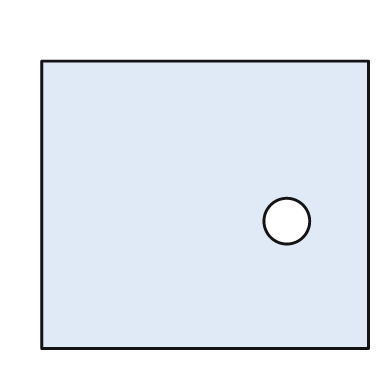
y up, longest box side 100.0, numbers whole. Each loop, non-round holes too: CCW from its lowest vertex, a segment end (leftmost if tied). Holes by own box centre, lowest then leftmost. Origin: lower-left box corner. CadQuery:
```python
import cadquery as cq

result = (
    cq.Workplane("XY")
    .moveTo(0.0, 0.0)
    .lineTo(100.0, 0.0)
    .lineTo(100.0, 88.0)
    .lineTo(0.0, 88.0)
    .close()
    .moveTo(75.0, 39.0)
    .circle(7.0)
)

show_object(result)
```